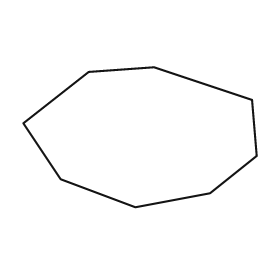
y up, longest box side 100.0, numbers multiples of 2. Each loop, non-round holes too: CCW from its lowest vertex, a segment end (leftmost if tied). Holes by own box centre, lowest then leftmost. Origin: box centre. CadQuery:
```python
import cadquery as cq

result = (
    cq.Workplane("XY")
    .moveTo(-2.0, -30.0)
    .lineTo(30.0, -24.0)
    .lineTo(50.0, -8.0)
    .lineTo(48.0, 16.0)
    .lineTo(6.0, 30.0)
    .lineTo(-22.0, 28.0)
    .lineTo(-50.0, 6.0)
    .lineTo(-34.0, -18.0)
    .close()
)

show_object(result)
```